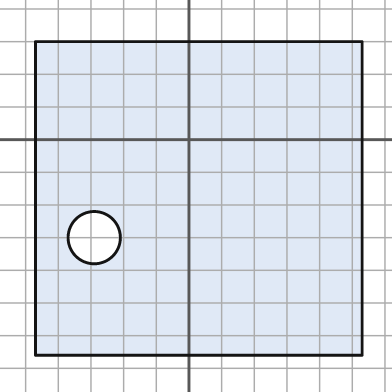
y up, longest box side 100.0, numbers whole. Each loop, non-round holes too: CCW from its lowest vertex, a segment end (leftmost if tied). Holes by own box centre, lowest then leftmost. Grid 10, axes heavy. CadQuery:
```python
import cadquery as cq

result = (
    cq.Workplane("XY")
    .moveTo(-47.0, -66.0)
    .lineTo(53.0, -66.0)
    .lineTo(53.0, 30.0)
    .lineTo(-47.0, 30.0)
    .close()
    .moveTo(-29.0, -30.0)
    .circle(8.0)
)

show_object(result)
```